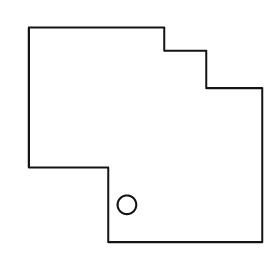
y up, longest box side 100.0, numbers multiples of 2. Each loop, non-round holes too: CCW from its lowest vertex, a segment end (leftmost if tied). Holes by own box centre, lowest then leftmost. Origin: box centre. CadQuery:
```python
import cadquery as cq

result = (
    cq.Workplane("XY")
    .moveTo(-16.0, -46.0)
    .lineTo(50.0, -46.0)
    .lineTo(50.0, 20.0)
    .lineTo(26.0, 20.0)
    .lineTo(26.0, 36.0)
    .lineTo(8.0, 36.0)
    .lineTo(8.0, 46.0)
    .lineTo(-50.0, 46.0)
    .lineTo(-50.0, -14.0)
    .lineTo(-16.0, -14.0)
    .close()
    .moveTo(-8.0, -30.0)
    .circle(4.0)
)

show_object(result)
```